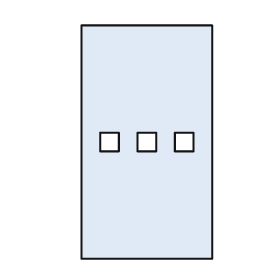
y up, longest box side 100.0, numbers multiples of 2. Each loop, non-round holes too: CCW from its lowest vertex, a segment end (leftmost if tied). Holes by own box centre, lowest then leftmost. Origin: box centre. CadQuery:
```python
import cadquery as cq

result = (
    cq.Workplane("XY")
    .moveTo(-28.0, -50.0)
    .lineTo(28.0, -50.0)
    .lineTo(28.0, 50.0)
    .lineTo(-28.0, 50.0)
    .close()
    .moveTo(-20.0, -4.0)
    .lineTo(-12.0, -4.0)
    .lineTo(-12.0, 4.0)
    .lineTo(-20.0, 4.0)
    .close()
    .moveTo(-4.0, -4.0)
    .lineTo(4.0, -4.0)
    .lineTo(4.0, 4.0)
    .lineTo(-4.0, 4.0)
    .close()
    .moveTo(12.0, -4.0)
    .lineTo(20.0, -4.0)
    .lineTo(20.0, 4.0)
    .lineTo(12.0, 4.0)
    .close()
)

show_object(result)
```